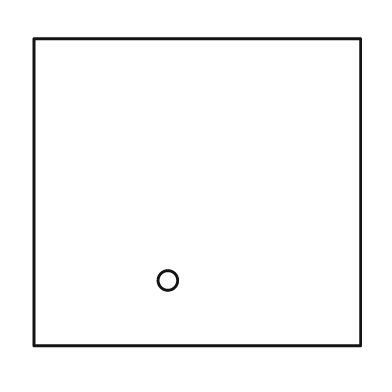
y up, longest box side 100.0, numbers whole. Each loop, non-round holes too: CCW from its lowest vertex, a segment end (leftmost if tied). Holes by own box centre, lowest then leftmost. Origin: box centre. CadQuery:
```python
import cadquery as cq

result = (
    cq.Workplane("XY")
    .moveTo(-50.0, -47.0)
    .lineTo(50.0, -47.0)
    .lineTo(50.0, 47.0)
    .lineTo(-50.0, 47.0)
    .close()
    .moveTo(-9.0, -27.0)
    .circle(3.0)
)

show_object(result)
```